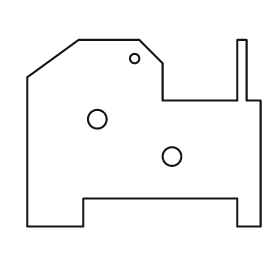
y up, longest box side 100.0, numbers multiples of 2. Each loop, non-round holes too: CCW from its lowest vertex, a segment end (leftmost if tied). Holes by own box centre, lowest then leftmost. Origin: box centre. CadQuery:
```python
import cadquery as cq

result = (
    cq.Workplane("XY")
    .moveTo(-50.0, -40.0)
    .lineTo(-26.0, -40.0)
    .lineTo(-26.0, -28.0)
    .lineTo(40.0, -28.0)
    .lineTo(40.0, -40.0)
    .lineTo(50.0, -40.0)
    .lineTo(50.0, 14.0)
    .lineTo(44.0, 14.0)
    .lineTo(44.0, 40.0)
    .lineTo(40.0, 40.0)
    .lineTo(40.0, 14.0)
    .lineTo(8.0, 14.0)
    .lineTo(8.0, 30.0)
    .lineTo(-2.0, 40.0)
    .lineTo(-28.0, 40.0)
    .lineTo(-50.0, 24.0)
    .close()
    .moveTo(12.0, -10.0)
    .circle(4.0)
    .moveTo(-20.0, 6.0)
    .circle(4.0)
    .moveTo(-4.0, 32.0)
    .circle(2.0)
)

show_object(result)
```